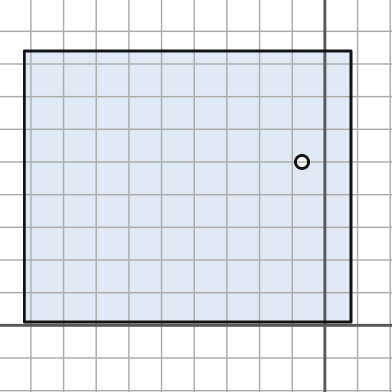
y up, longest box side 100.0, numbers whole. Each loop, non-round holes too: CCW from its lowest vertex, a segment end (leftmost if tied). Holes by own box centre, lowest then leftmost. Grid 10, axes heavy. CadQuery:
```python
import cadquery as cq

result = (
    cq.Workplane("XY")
    .moveTo(-92.0, 1.0)
    .lineTo(8.0, 1.0)
    .lineTo(8.0, 84.0)
    .lineTo(-92.0, 84.0)
    .close()
    .moveTo(-7.0, 50.0)
    .circle(2.0)
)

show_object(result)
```